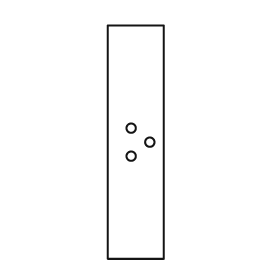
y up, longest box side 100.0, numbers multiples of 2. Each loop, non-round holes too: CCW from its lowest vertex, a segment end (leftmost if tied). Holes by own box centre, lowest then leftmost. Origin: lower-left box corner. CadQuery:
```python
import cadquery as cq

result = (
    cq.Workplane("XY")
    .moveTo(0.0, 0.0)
    .lineTo(24.0, 0.0)
    .lineTo(24.0, 100.0)
    .lineTo(0.0, 100.0)
    .close()
    .moveTo(10.0, 44.0)
    .circle(2.0)
    .moveTo(18.0, 50.0)
    .circle(2.0)
    .moveTo(10.0, 56.0)
    .circle(2.0)
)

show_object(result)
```